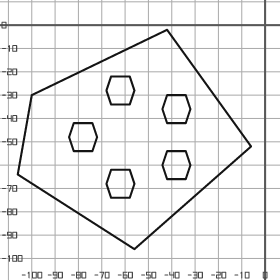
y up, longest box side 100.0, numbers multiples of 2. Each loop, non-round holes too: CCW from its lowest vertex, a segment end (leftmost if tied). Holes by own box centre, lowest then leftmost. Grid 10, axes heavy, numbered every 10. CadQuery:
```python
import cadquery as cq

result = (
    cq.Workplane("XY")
    .moveTo(-56.0, -96.0)
    .lineTo(-6.0, -52.0)
    .lineTo(-42.0, -2.0)
    .lineTo(-100.0, -30.0)
    .lineTo(-106.0, -64.0)
    .close()
    .moveTo(-66.0, -74.0)
    .lineTo(-58.0, -74.0)
    .lineTo(-56.0, -68.0)
    .lineTo(-58.0, -62.0)
    .lineTo(-66.0, -62.0)
    .lineTo(-68.0, -68.0)
    .close()
    .moveTo(-42.0, -66.0)
    .lineTo(-34.0, -66.0)
    .lineTo(-32.0, -60.0)
    .lineTo(-34.0, -54.0)
    .lineTo(-42.0, -54.0)
    .lineTo(-44.0, -60.0)
    .close()
    .moveTo(-82.0, -54.0)
    .lineTo(-74.0, -54.0)
    .lineTo(-72.0, -48.0)
    .lineTo(-74.0, -42.0)
    .lineTo(-82.0, -42.0)
    .lineTo(-84.0, -48.0)
    .close()
    .moveTo(-42.0, -42.0)
    .lineTo(-34.0, -42.0)
    .lineTo(-32.0, -36.0)
    .lineTo(-34.0, -30.0)
    .lineTo(-42.0, -30.0)
    .lineTo(-44.0, -36.0)
    .close()
    .moveTo(-66.0, -34.0)
    .lineTo(-58.0, -34.0)
    .lineTo(-56.0, -28.0)
    .lineTo(-58.0, -22.0)
    .lineTo(-66.0, -22.0)
    .lineTo(-68.0, -28.0)
    .close()
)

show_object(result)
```